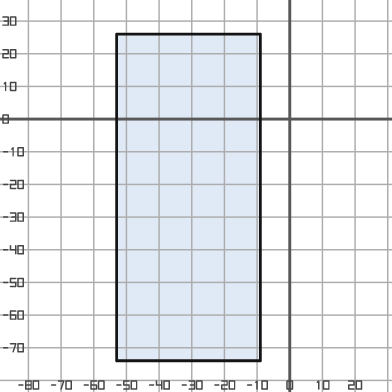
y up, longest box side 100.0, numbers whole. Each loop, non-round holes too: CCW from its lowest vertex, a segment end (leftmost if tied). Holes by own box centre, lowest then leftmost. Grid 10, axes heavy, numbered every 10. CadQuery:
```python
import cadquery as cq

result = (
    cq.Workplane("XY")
    .moveTo(-53.0, -74.0)
    .lineTo(-9.0, -74.0)
    .lineTo(-9.0, 26.0)
    .lineTo(-53.0, 26.0)
    .close()
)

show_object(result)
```